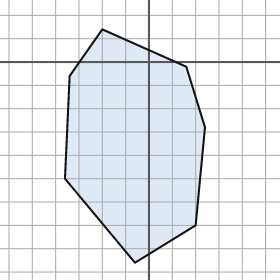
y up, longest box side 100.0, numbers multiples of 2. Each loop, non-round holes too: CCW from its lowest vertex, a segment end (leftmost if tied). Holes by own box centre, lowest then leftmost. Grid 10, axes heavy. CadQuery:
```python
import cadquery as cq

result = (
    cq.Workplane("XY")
    .moveTo(-6.0, -86.0)
    .lineTo(20.0, -70.0)
    .lineTo(24.0, -28.0)
    .lineTo(16.0, -2.0)
    .lineTo(-20.0, 14.0)
    .lineTo(-34.0, -6.0)
    .lineTo(-36.0, -50.0)
    .close()
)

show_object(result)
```